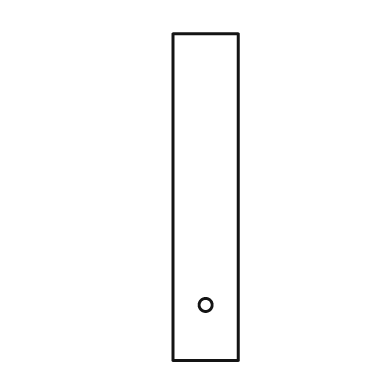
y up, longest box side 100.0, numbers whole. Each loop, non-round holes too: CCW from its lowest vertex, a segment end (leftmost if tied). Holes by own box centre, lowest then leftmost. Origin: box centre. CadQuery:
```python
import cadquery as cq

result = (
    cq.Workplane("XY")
    .moveTo(-10.0, -50.0)
    .lineTo(10.0, -50.0)
    .lineTo(10.0, 50.0)
    .lineTo(-10.0, 50.0)
    .close()
    .moveTo(0.0, -33.0)
    .circle(2.0)
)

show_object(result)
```